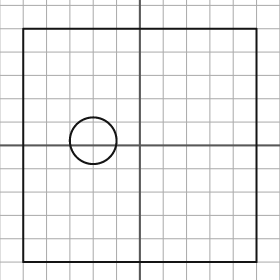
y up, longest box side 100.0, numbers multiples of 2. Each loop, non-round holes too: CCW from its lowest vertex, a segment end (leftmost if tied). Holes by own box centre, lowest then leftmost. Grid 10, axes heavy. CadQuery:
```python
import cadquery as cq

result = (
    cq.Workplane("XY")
    .moveTo(-50.0, -50.0)
    .lineTo(50.0, -50.0)
    .lineTo(50.0, 50.0)
    .lineTo(-50.0, 50.0)
    .close()
    .moveTo(-20.0, 2.0)
    .circle(10.0)
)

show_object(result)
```